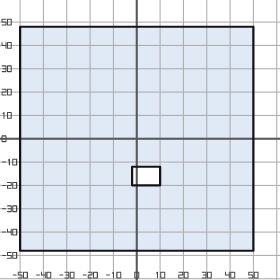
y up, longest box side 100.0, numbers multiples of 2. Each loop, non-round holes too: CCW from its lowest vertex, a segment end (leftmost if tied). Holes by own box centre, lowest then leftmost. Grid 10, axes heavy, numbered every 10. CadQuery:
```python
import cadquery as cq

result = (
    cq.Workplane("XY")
    .moveTo(-50.0, -48.0)
    .lineTo(50.0, -48.0)
    .lineTo(50.0, 48.0)
    .lineTo(-50.0, 48.0)
    .close()
    .moveTo(-2.0, -20.0)
    .lineTo(10.0, -20.0)
    .lineTo(10.0, -12.0)
    .lineTo(-2.0, -12.0)
    .close()
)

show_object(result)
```